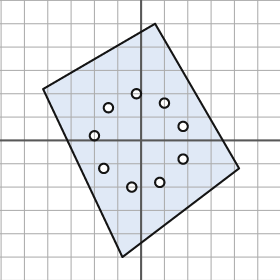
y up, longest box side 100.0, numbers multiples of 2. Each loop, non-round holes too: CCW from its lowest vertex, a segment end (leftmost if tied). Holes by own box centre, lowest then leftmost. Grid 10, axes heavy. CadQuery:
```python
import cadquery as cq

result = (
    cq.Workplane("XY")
    .moveTo(-8.0, -50.0)
    .lineTo(42.0, -12.0)
    .lineTo(6.0, 50.0)
    .lineTo(-42.0, 22.0)
    .close()
    .moveTo(-4.0, -20.0)
    .circle(2.0)
    .moveTo(8.0, -18.0)
    .circle(2.0)
    .moveTo(-16.0, -12.0)
    .circle(2.0)
    .moveTo(18.0, -8.0)
    .circle(2.0)
    .moveTo(-20.0, 2.0)
    .circle(2.0)
    .moveTo(18.0, 6.0)
    .circle(2.0)
    .moveTo(-14.0, 14.0)
    .circle(2.0)
    .moveTo(10.0, 16.0)
    .circle(2.0)
    .moveTo(-2.0, 20.0)
    .circle(2.0)
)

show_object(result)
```